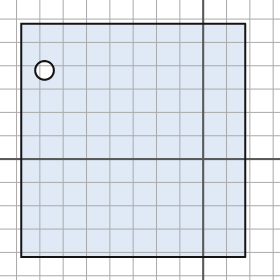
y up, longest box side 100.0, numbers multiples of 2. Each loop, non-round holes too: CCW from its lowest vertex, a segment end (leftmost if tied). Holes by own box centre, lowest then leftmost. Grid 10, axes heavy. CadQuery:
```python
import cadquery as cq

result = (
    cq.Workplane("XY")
    .moveTo(-78.0, -42.0)
    .lineTo(18.0, -42.0)
    .lineTo(18.0, 58.0)
    .lineTo(-78.0, 58.0)
    .close()
    .moveTo(-68.0, 38.0)
    .circle(4.0)
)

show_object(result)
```